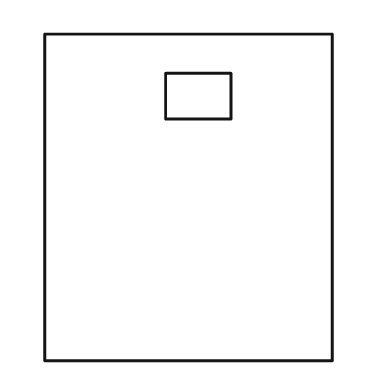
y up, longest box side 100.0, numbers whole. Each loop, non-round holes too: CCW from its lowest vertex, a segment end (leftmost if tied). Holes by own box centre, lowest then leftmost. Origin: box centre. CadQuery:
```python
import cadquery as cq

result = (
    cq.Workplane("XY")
    .moveTo(-44.0, -50.0)
    .lineTo(44.0, -50.0)
    .lineTo(44.0, 50.0)
    .lineTo(-44.0, 50.0)
    .close()
    .moveTo(-7.0, 24.0)
    .lineTo(13.0, 24.0)
    .lineTo(13.0, 38.0)
    .lineTo(-7.0, 38.0)
    .close()
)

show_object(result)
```